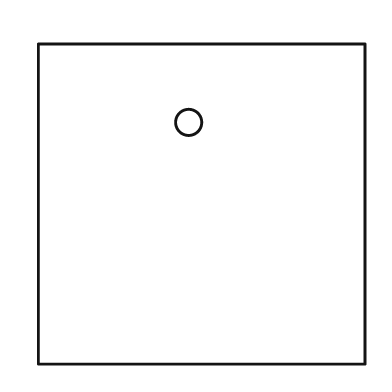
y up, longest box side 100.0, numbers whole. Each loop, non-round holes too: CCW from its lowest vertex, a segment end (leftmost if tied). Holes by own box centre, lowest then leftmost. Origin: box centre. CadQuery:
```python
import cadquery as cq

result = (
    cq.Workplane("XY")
    .moveTo(-50.0, -49.0)
    .lineTo(50.0, -49.0)
    .lineTo(50.0, 49.0)
    .lineTo(-50.0, 49.0)
    .close()
    .moveTo(-4.0, 25.0)
    .circle(4.0)
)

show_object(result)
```